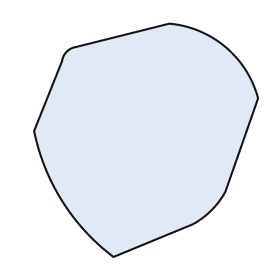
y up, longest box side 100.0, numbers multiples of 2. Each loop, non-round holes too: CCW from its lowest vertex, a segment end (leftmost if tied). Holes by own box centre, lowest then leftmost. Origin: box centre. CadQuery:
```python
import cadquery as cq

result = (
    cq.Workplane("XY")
    .moveTo(-14.0, -50.0)
    .lineTo(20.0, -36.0)
    .threePointArc((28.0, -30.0), (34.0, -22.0))
    .lineTo(48.0, 18.0)
    .threePointArc((34.0, 40.0), (10.0, 50.0))
    .lineTo(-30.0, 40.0)
    .threePointArc((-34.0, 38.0), (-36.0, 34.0))
    .lineTo(-48.0, 4.0)
    .threePointArc((-36.0, -26.0), (-14.0, -50.0))
    .close()
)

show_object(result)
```